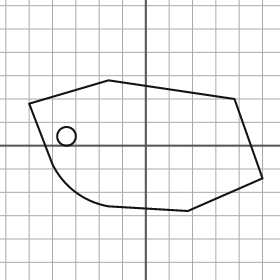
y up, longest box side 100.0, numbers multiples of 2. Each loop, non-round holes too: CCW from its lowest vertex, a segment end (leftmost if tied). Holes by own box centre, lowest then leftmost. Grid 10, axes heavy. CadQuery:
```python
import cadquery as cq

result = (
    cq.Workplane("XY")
    .moveTo(18.0, -28.0)
    .lineTo(50.0, -14.0)
    .lineTo(38.0, 20.0)
    .lineTo(-16.0, 28.0)
    .lineTo(-50.0, 18.0)
    .lineTo(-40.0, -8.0)
    .threePointArc((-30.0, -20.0), (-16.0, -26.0))
    .close()
    .moveTo(-34.0, 4.0)
    .circle(4.0)
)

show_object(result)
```